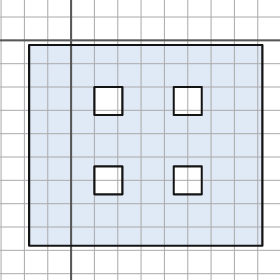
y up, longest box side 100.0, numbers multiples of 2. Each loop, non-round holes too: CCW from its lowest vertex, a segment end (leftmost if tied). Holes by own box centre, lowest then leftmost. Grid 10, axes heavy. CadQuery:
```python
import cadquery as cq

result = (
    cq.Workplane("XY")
    .moveTo(-18.0, -88.0)
    .lineTo(82.0, -88.0)
    .lineTo(82.0, -2.0)
    .lineTo(-18.0, -2.0)
    .close()
    .moveTo(10.0, -66.0)
    .lineTo(22.0, -66.0)
    .lineTo(22.0, -54.0)
    .lineTo(10.0, -54.0)
    .close()
    .moveTo(44.0, -66.0)
    .lineTo(56.0, -66.0)
    .lineTo(56.0, -54.0)
    .lineTo(44.0, -54.0)
    .close()
    .moveTo(10.0, -32.0)
    .lineTo(22.0, -32.0)
    .lineTo(22.0, -20.0)
    .lineTo(10.0, -20.0)
    .close()
    .moveTo(44.0, -32.0)
    .lineTo(56.0, -32.0)
    .lineTo(56.0, -20.0)
    .lineTo(44.0, -20.0)
    .close()
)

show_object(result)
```